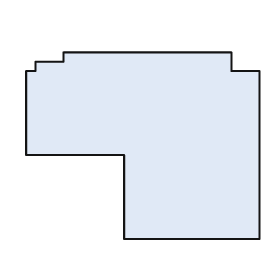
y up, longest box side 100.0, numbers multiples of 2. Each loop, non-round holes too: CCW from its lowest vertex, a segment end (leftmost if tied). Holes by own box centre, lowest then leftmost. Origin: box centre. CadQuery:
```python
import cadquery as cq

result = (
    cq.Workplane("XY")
    .moveTo(-8.0, -40.0)
    .lineTo(50.0, -40.0)
    .lineTo(50.0, 32.0)
    .lineTo(38.0, 32.0)
    .lineTo(38.0, 40.0)
    .lineTo(-34.0, 40.0)
    .lineTo(-34.0, 36.0)
    .lineTo(-46.0, 36.0)
    .lineTo(-46.0, 32.0)
    .lineTo(-50.0, 32.0)
    .lineTo(-50.0, -4.0)
    .lineTo(-8.0, -4.0)
    .close()
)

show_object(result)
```